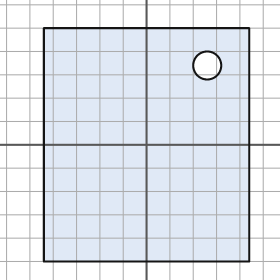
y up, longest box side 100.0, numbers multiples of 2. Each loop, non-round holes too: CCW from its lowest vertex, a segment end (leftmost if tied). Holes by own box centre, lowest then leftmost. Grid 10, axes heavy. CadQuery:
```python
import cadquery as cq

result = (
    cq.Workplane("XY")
    .moveTo(-44.0, -50.0)
    .lineTo(44.0, -50.0)
    .lineTo(44.0, 50.0)
    .lineTo(-44.0, 50.0)
    .close()
    .moveTo(26.0, 34.0)
    .circle(6.0)
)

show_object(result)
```